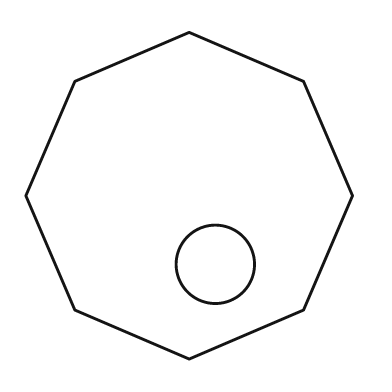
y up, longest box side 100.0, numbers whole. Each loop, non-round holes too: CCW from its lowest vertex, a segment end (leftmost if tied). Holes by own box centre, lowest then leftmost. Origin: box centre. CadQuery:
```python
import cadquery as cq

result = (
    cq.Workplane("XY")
    .moveTo(0.0, -50.0)
    .lineTo(35.0, -35.0)
    .lineTo(50.0, 0.0)
    .lineTo(35.0, 35.0)
    .lineTo(0.0, 50.0)
    .lineTo(-35.0, 35.0)
    .lineTo(-50.0, 0.0)
    .lineTo(-35.0, -35.0)
    .close()
    .moveTo(8.0, -21.0)
    .circle(12.0)
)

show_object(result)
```